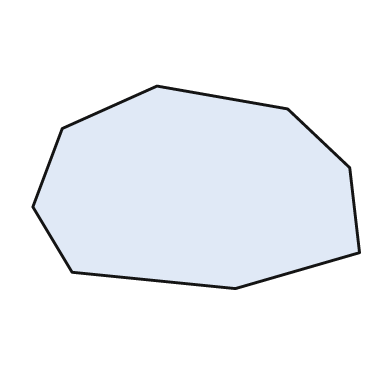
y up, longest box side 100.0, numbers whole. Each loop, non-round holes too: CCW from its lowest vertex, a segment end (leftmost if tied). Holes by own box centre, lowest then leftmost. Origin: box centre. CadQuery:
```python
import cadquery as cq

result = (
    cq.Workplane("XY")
    .moveTo(12.0, -31.0)
    .lineTo(50.0, -20.0)
    .lineTo(47.0, 6.0)
    .lineTo(28.0, 24.0)
    .lineTo(-12.0, 31.0)
    .lineTo(-41.0, 18.0)
    .lineTo(-50.0, -6.0)
    .lineTo(-38.0, -26.0)
    .close()
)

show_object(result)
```